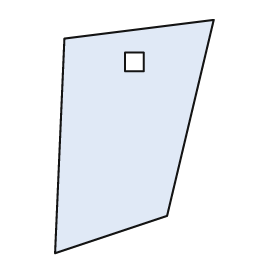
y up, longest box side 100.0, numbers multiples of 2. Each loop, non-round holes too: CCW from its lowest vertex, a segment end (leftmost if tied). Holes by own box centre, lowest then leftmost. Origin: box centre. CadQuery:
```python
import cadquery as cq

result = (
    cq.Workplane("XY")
    .moveTo(-34.0, -50.0)
    .lineTo(14.0, -34.0)
    .lineTo(34.0, 50.0)
    .lineTo(-30.0, 42.0)
    .close()
    .moveTo(-4.0, 28.0)
    .lineTo(4.0, 28.0)
    .lineTo(4.0, 36.0)
    .lineTo(-4.0, 36.0)
    .close()
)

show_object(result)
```